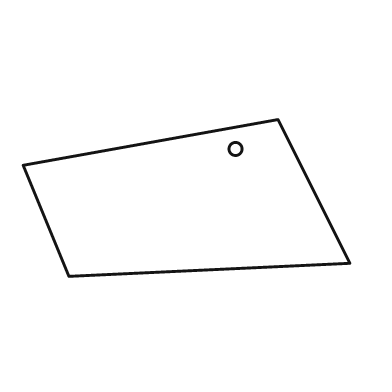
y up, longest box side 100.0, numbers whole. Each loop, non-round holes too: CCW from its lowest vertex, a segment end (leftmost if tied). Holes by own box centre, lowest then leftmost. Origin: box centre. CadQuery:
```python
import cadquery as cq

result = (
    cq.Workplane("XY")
    .moveTo(-36.0, -24.0)
    .lineTo(50.0, -20.0)
    .lineTo(28.0, 24.0)
    .lineTo(-50.0, 10.0)
    .close()
    .moveTo(15.0, 15.0)
    .circle(2.0)
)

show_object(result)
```